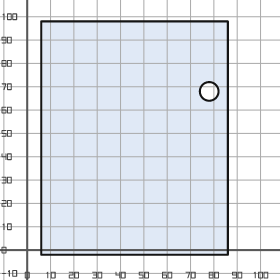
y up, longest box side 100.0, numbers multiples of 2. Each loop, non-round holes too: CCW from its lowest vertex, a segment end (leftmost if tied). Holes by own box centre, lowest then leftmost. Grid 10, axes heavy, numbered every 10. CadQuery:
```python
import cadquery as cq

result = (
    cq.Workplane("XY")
    .moveTo(6.0, -2.0)
    .lineTo(86.0, -2.0)
    .lineTo(86.0, 98.0)
    .lineTo(6.0, 98.0)
    .close()
    .moveTo(78.0, 68.0)
    .circle(4.0)
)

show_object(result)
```